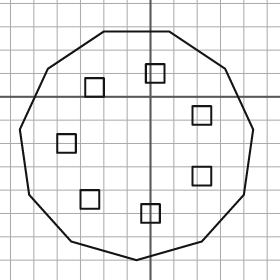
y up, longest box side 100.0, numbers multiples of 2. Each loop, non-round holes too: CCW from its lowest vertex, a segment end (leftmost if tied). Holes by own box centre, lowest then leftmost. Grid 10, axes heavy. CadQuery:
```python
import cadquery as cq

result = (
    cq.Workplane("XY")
    .moveTo(-6.0, -70.0)
    .lineTo(22.0, -62.0)
    .lineTo(40.0, -42.0)
    .lineTo(44.0, -14.0)
    .lineTo(32.0, 12.0)
    .lineTo(8.0, 28.0)
    .lineTo(-20.0, 28.0)
    .lineTo(-44.0, 12.0)
    .lineTo(-56.0, -14.0)
    .lineTo(-52.0, -42.0)
    .lineTo(-34.0, -62.0)
    .close()
    .moveTo(-4.0, -54.0)
    .lineTo(4.0, -54.0)
    .lineTo(4.0, -46.0)
    .lineTo(-4.0, -46.0)
    .close()
    .moveTo(-30.0, -48.0)
    .lineTo(-22.0, -48.0)
    .lineTo(-22.0, -40.0)
    .lineTo(-30.0, -40.0)
    .close()
    .moveTo(18.0, -38.0)
    .lineTo(26.0, -38.0)
    .lineTo(26.0, -30.0)
    .lineTo(18.0, -30.0)
    .close()
    .moveTo(-40.0, -24.0)
    .lineTo(-32.0, -24.0)
    .lineTo(-32.0, -16.0)
    .lineTo(-40.0, -16.0)
    .close()
    .moveTo(18.0, -12.0)
    .lineTo(26.0, -12.0)
    .lineTo(26.0, -4.0)
    .lineTo(18.0, -4.0)
    .close()
    .moveTo(-28.0, 0.0)
    .lineTo(-20.0, 0.0)
    .lineTo(-20.0, 8.0)
    .lineTo(-28.0, 8.0)
    .close()
    .moveTo(-2.0, 6.0)
    .lineTo(6.0, 6.0)
    .lineTo(6.0, 14.0)
    .lineTo(-2.0, 14.0)
    .close()
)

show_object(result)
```